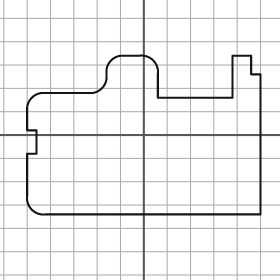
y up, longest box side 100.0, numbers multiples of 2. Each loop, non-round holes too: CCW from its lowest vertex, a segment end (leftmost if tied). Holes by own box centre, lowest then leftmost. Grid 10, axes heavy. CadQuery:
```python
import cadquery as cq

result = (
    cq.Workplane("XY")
    .moveTo(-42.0, -34.0)
    .lineTo(50.0, -34.0)
    .lineTo(50.0, 26.0)
    .lineTo(46.0, 26.0)
    .lineTo(46.0, 34.0)
    .lineTo(38.0, 34.0)
    .lineTo(38.0, 16.0)
    .lineTo(6.0, 16.0)
    .lineTo(6.0, 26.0)
    .threePointArc((4.0, 32.0), (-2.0, 34.0))
    .lineTo(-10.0, 34.0)
    .threePointArc((-14.0, 32.0), (-16.0, 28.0))
    .lineTo(-16.0, 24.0)
    .threePointArc((-18.0, 20.0), (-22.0, 18.0))
    .lineTo(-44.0, 18.0)
    .threePointArc((-48.0, 16.0), (-50.0, 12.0))
    .lineTo(-50.0, 2.0)
    .lineTo(-46.0, 2.0)
    .lineTo(-46.0, -8.0)
    .lineTo(-50.0, -8.0)
    .lineTo(-50.0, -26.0)
    .threePointArc((-48.0, -32.0), (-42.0, -34.0))
    .close()
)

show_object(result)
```